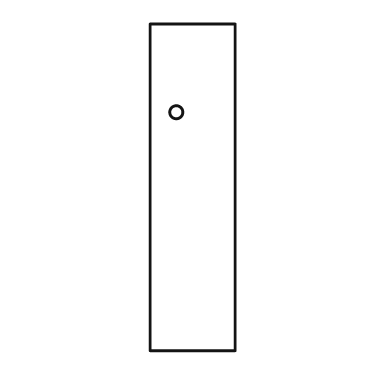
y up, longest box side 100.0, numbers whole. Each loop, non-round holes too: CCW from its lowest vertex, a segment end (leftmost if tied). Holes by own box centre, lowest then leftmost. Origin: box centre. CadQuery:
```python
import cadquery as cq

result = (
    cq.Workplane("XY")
    .moveTo(-13.0, -50.0)
    .lineTo(13.0, -50.0)
    .lineTo(13.0, 50.0)
    .lineTo(-13.0, 50.0)
    .close()
    .moveTo(-5.0, 23.0)
    .circle(2.0)
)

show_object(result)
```